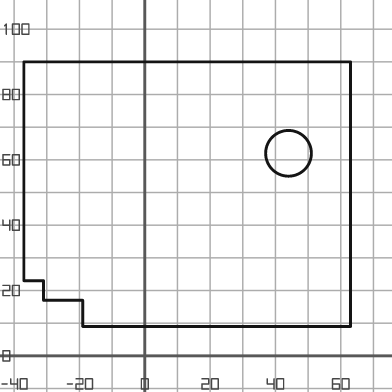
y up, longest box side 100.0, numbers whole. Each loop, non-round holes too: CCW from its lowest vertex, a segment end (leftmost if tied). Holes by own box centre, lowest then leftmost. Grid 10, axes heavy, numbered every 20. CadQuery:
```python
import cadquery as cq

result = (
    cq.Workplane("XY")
    .moveTo(-19.0, 9.0)
    .lineTo(63.0, 9.0)
    .lineTo(63.0, 90.0)
    .lineTo(-37.0, 90.0)
    .lineTo(-37.0, 23.0)
    .lineTo(-31.0, 23.0)
    .lineTo(-31.0, 17.0)
    .lineTo(-19.0, 17.0)
    .close()
    .moveTo(44.0, 62.0)
    .circle(7.0)
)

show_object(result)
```